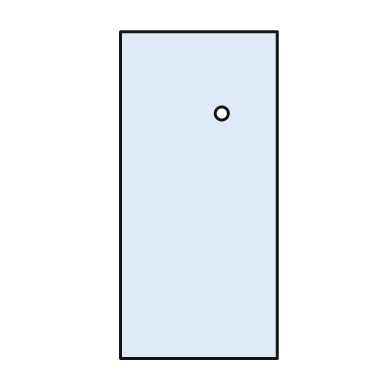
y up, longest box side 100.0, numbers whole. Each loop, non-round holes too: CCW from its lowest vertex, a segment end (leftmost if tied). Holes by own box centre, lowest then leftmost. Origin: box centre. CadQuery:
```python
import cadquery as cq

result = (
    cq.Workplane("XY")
    .moveTo(-24.0, -50.0)
    .lineTo(24.0, -50.0)
    .lineTo(24.0, 50.0)
    .lineTo(-24.0, 50.0)
    .close()
    .moveTo(7.0, 25.0)
    .circle(2.0)
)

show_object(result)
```